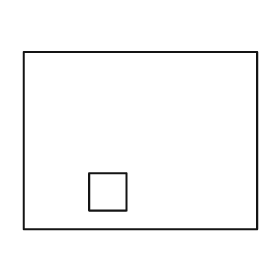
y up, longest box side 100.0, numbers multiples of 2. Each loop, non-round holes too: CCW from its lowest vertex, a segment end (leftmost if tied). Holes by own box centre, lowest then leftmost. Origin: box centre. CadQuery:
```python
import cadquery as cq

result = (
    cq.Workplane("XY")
    .moveTo(-50.0, -38.0)
    .lineTo(50.0, -38.0)
    .lineTo(50.0, 38.0)
    .lineTo(-50.0, 38.0)
    .close()
    .moveTo(-22.0, -30.0)
    .lineTo(-6.0, -30.0)
    .lineTo(-6.0, -14.0)
    .lineTo(-22.0, -14.0)
    .close()
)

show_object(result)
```